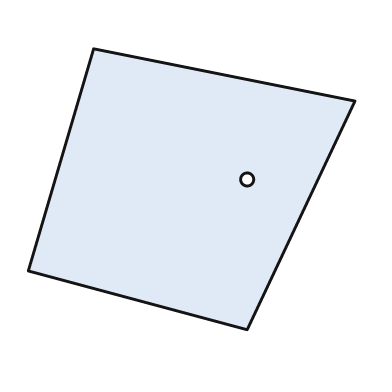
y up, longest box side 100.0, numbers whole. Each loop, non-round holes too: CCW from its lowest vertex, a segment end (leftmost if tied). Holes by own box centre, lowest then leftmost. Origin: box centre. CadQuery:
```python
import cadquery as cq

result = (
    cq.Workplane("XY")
    .moveTo(17.0, -43.0)
    .lineTo(50.0, 27.0)
    .lineTo(-30.0, 43.0)
    .lineTo(-50.0, -25.0)
    .close()
    .moveTo(17.0, 3.0)
    .circle(2.0)
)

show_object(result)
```